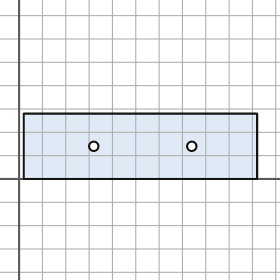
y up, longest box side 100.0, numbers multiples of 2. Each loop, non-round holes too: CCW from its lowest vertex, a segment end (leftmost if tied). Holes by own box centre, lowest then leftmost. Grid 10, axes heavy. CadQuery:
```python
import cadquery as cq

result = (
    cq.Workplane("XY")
    .moveTo(2.0, 0.0)
    .lineTo(102.0, 0.0)
    .lineTo(102.0, 28.0)
    .lineTo(2.0, 28.0)
    .close()
    .moveTo(32.0, 14.0)
    .circle(2.0)
    .moveTo(74.0, 14.0)
    .circle(2.0)
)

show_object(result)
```